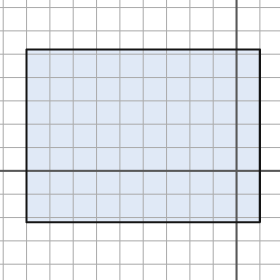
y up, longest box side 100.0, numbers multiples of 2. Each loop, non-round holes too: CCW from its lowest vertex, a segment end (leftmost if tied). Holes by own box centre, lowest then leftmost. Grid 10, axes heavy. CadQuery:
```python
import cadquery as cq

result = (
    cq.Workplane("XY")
    .moveTo(-90.0, -22.0)
    .lineTo(10.0, -22.0)
    .lineTo(10.0, 52.0)
    .lineTo(-90.0, 52.0)
    .close()
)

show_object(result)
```